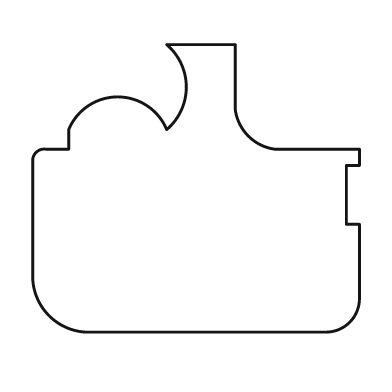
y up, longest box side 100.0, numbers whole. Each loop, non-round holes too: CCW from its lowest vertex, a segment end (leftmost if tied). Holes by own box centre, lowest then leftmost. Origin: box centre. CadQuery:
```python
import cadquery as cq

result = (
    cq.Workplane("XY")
    .moveTo(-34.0, -44.0)
    .lineTo(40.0, -44.0)
    .threePointArc((47.0, -41.0), (50.0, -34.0))
    .lineTo(50.0, -11.0)
    .lineTo(46.0, -11.0)
    .lineTo(46.0, 7.0)
    .lineTo(50.0, 7.0)
    .lineTo(50.0, 12.0)
    .lineTo(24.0, 12.0)
    .threePointArc((16.0, 16.0), (12.0, 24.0))
    .lineTo(12.0, 44.0)
    .lineTo(-9.0, 44.0)
    .threePointArc((-3.0, 31.0), (-9.0, 18.0))
    .threePointArc((-24.0, 28.0), (-39.0, 18.0))
    .lineTo(-39.0, 12.0)
    .lineTo(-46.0, 12.0)
    .threePointArc((-49.0, 11.0), (-50.0, 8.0))
    .lineTo(-50.0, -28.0)
    .threePointArc((-45.0, -39.0), (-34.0, -44.0))
    .close()
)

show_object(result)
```